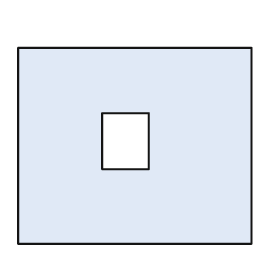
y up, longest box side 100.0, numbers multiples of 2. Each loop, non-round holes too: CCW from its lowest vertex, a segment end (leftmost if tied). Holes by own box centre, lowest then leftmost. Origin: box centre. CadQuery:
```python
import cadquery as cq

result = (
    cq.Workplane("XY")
    .moveTo(-50.0, -42.0)
    .lineTo(50.0, -42.0)
    .lineTo(50.0, 42.0)
    .lineTo(-50.0, 42.0)
    .close()
    .moveTo(-14.0, -10.0)
    .lineTo(6.0, -10.0)
    .lineTo(6.0, 14.0)
    .lineTo(-14.0, 14.0)
    .close()
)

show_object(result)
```